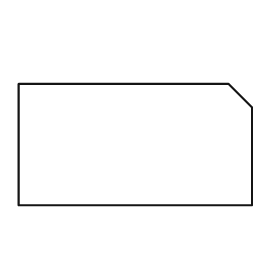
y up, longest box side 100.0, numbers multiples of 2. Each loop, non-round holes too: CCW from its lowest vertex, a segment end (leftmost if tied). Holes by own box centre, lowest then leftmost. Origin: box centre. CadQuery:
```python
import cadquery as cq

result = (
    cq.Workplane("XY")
    .moveTo(-50.0, -26.0)
    .lineTo(50.0, -26.0)
    .lineTo(50.0, 16.0)
    .lineTo(40.0, 26.0)
    .lineTo(-50.0, 26.0)
    .close()
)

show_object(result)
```